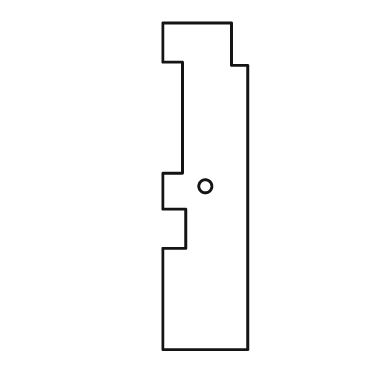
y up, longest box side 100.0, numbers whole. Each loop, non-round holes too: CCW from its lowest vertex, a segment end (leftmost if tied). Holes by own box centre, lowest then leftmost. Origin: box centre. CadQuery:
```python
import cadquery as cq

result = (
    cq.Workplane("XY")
    .moveTo(-13.0, -50.0)
    .lineTo(13.0, -50.0)
    .lineTo(13.0, 37.0)
    .lineTo(8.0, 37.0)
    .lineTo(8.0, 50.0)
    .lineTo(-13.0, 50.0)
    .lineTo(-13.0, 38.0)
    .lineTo(-7.0, 38.0)
    .lineTo(-7.0, 4.0)
    .lineTo(-13.0, 4.0)
    .lineTo(-13.0, -7.0)
    .lineTo(-6.0, -7.0)
    .lineTo(-6.0, -19.0)
    .lineTo(-13.0, -19.0)
    .close()
    .moveTo(0.0, 0.0)
    .circle(2.0)
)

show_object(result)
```